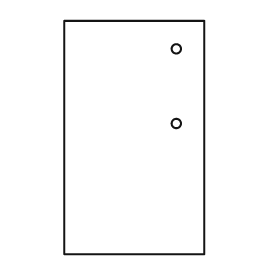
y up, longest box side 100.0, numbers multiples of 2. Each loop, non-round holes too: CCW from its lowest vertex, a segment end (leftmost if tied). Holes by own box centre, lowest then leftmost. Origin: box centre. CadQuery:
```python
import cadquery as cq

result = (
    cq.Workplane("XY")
    .moveTo(-30.0, -50.0)
    .lineTo(30.0, -50.0)
    .lineTo(30.0, 50.0)
    .lineTo(-30.0, 50.0)
    .close()
    .moveTo(18.0, 6.0)
    .circle(2.0)
    .moveTo(18.0, 38.0)
    .circle(2.0)
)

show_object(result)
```